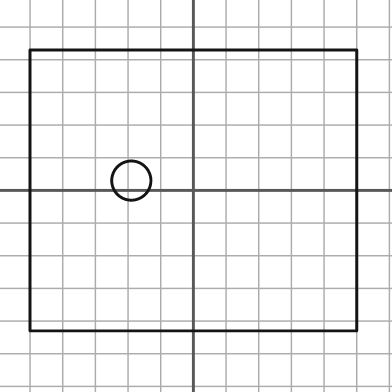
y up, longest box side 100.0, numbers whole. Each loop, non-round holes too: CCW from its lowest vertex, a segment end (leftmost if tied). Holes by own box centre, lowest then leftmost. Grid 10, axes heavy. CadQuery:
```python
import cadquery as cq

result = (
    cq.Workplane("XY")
    .moveTo(-50.0, -43.0)
    .lineTo(50.0, -43.0)
    .lineTo(50.0, 43.0)
    .lineTo(-50.0, 43.0)
    .close()
    .moveTo(-19.0, 3.0)
    .circle(6.0)
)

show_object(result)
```